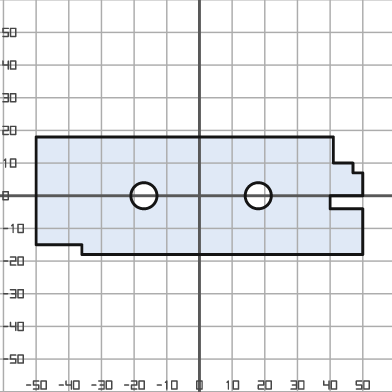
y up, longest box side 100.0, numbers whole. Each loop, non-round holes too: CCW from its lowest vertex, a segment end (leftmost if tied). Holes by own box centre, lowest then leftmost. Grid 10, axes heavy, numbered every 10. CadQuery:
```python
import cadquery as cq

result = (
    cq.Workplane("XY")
    .moveTo(-36.0, -18.0)
    .lineTo(50.0, -18.0)
    .lineTo(50.0, -4.0)
    .lineTo(40.0, -4.0)
    .lineTo(40.0, 0.0)
    .lineTo(50.0, 0.0)
    .lineTo(50.0, 7.0)
    .lineTo(47.0, 7.0)
    .lineTo(47.0, 10.0)
    .lineTo(41.0, 10.0)
    .lineTo(41.0, 18.0)
    .lineTo(-50.0, 18.0)
    .lineTo(-50.0, -15.0)
    .lineTo(-36.0, -15.0)
    .close()
    .moveTo(-17.0, 0.0)
    .circle(4.0)
    .moveTo(18.0, 0.0)
    .circle(4.0)
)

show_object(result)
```